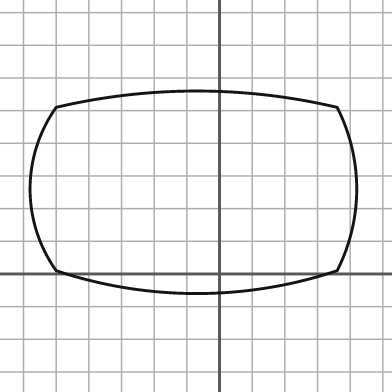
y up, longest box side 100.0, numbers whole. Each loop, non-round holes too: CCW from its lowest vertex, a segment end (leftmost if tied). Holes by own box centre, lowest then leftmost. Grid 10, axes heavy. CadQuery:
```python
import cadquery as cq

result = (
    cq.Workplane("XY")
    .moveTo(-50.0, 1.0)
    .threePointArc((-7.0, -6.0), (36.0, 1.0))
    .threePointArc((42.0, 26.0), (36.0, 51.0))
    .threePointArc((-7.0, 56.0), (-50.0, 51.0))
    .threePointArc((-58.0, 26.0), (-50.0, 1.0))
    .close()
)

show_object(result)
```